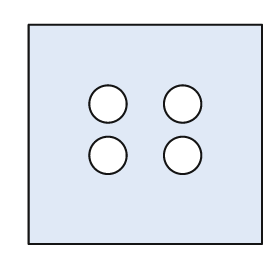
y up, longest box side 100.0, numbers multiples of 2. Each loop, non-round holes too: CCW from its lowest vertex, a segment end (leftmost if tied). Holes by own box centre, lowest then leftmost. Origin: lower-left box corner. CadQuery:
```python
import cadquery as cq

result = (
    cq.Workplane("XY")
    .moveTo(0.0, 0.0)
    .lineTo(100.0, 0.0)
    .lineTo(100.0, 94.0)
    .lineTo(0.0, 94.0)
    .close()
    .moveTo(34.0, 38.0)
    .circle(8.0)
    .moveTo(66.0, 38.0)
    .circle(8.0)
    .moveTo(34.0, 60.0)
    .circle(8.0)
    .moveTo(66.0, 60.0)
    .circle(8.0)
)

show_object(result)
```